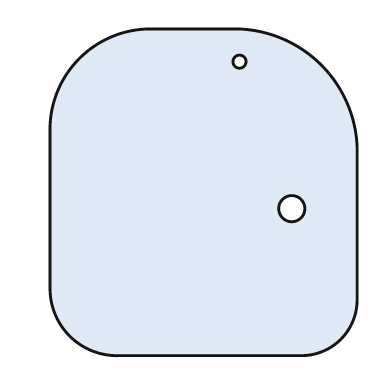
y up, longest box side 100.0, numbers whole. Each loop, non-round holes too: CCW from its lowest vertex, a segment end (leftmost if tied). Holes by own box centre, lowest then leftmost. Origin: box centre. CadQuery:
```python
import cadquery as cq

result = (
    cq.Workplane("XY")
    .moveTo(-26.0, -50.0)
    .lineTo(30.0, -50.0)
    .threePointArc((42.0, -45.0), (47.0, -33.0))
    .lineTo(47.0, 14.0)
    .threePointArc((36.0, 39.0), (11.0, 50.0))
    .lineTo(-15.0, 50.0)
    .threePointArc((-38.0, 41.0), (-47.0, 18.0))
    .lineTo(-47.0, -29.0)
    .threePointArc((-41.0, -44.0), (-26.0, -50.0))
    .close()
    .moveTo(27.0, -5.0)
    .circle(4.0)
    .moveTo(11.0, 40.0)
    .circle(2.0)
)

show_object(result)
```